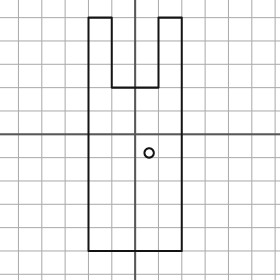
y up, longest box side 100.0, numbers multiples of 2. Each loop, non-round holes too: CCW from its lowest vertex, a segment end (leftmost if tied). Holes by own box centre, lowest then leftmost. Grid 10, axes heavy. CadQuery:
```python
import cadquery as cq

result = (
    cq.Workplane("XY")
    .moveTo(-20.0, -50.0)
    .lineTo(20.0, -50.0)
    .lineTo(20.0, 50.0)
    .lineTo(10.0, 50.0)
    .lineTo(10.0, 20.0)
    .lineTo(-10.0, 20.0)
    .lineTo(-10.0, 50.0)
    .lineTo(-20.0, 50.0)
    .close()
    .moveTo(6.0, -8.0)
    .circle(2.0)
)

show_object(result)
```